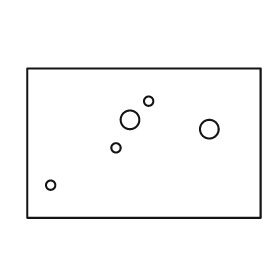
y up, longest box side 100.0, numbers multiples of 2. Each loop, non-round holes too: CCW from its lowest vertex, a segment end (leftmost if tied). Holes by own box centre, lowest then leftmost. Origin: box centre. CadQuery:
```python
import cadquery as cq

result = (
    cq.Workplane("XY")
    .moveTo(-50.0, -32.0)
    .lineTo(50.0, -32.0)
    .lineTo(50.0, 32.0)
    .lineTo(-50.0, 32.0)
    .close()
    .moveTo(-40.0, -18.0)
    .circle(2.0)
    .moveTo(-12.0, -2.0)
    .circle(2.0)
    .moveTo(28.0, 6.0)
    .circle(4.0)
    .moveTo(-6.0, 10.0)
    .circle(4.0)
    .moveTo(2.0, 18.0)
    .circle(2.0)
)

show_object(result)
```